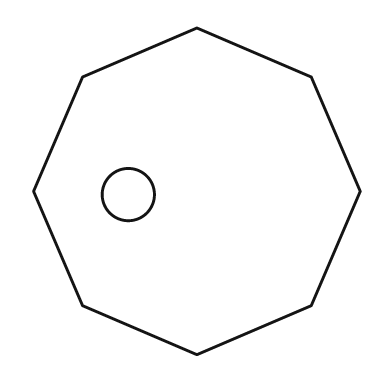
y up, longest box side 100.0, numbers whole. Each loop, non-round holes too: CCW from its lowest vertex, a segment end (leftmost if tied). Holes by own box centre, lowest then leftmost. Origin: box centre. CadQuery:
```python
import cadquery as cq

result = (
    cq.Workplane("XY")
    .moveTo(0.0, -50.0)
    .lineTo(35.0, -35.0)
    .lineTo(50.0, 0.0)
    .lineTo(35.0, 35.0)
    .lineTo(0.0, 50.0)
    .lineTo(-35.0, 35.0)
    .lineTo(-50.0, 0.0)
    .lineTo(-35.0, -35.0)
    .close()
    .moveTo(-21.0, -1.0)
    .circle(8.0)
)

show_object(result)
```